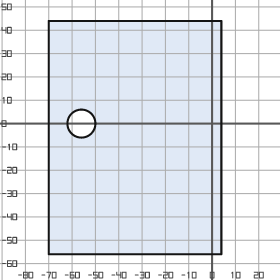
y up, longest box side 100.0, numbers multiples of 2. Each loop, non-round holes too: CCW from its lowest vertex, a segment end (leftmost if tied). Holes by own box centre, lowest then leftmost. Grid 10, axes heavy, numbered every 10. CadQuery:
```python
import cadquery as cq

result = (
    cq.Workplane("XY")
    .moveTo(-70.0, -56.0)
    .lineTo(4.0, -56.0)
    .lineTo(4.0, 44.0)
    .lineTo(-70.0, 44.0)
    .close()
    .moveTo(-56.0, 0.0)
    .circle(6.0)
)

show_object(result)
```